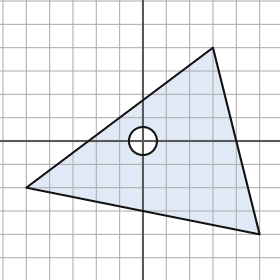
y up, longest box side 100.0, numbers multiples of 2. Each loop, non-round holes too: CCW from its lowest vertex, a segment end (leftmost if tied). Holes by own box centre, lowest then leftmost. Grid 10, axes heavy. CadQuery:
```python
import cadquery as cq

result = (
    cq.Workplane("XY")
    .moveTo(50.0, -40.0)
    .lineTo(30.0, 40.0)
    .lineTo(-50.0, -20.0)
    .close()
    .moveTo(0.0, 0.0)
    .circle(6.0)
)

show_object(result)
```